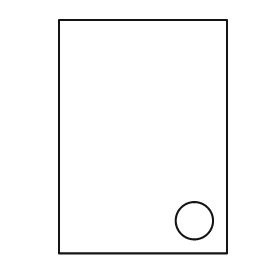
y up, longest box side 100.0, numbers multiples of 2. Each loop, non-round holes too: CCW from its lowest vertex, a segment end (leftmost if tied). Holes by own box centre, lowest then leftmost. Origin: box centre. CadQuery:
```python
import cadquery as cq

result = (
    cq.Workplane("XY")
    .moveTo(-36.0, -50.0)
    .lineTo(36.0, -50.0)
    .lineTo(36.0, 50.0)
    .lineTo(-36.0, 50.0)
    .close()
    .moveTo(22.0, -36.0)
    .circle(8.0)
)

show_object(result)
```